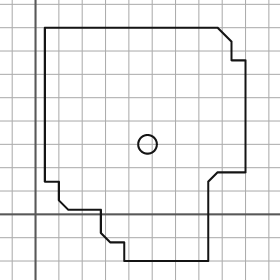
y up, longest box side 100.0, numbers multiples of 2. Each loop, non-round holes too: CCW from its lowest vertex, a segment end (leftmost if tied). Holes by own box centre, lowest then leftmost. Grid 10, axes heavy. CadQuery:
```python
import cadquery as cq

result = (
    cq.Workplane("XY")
    .moveTo(38.0, -20.0)
    .lineTo(74.0, -20.0)
    .lineTo(74.0, 14.0)
    .lineTo(78.0, 18.0)
    .lineTo(90.0, 18.0)
    .lineTo(90.0, 66.0)
    .lineTo(84.0, 66.0)
    .lineTo(84.0, 74.0)
    .lineTo(78.0, 80.0)
    .lineTo(4.0, 80.0)
    .lineTo(4.0, 14.0)
    .lineTo(10.0, 14.0)
    .lineTo(10.0, 6.0)
    .lineTo(14.0, 2.0)
    .lineTo(28.0, 2.0)
    .lineTo(28.0, -8.0)
    .lineTo(32.0, -12.0)
    .lineTo(38.0, -12.0)
    .close()
    .moveTo(48.0, 30.0)
    .circle(4.0)
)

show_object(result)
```